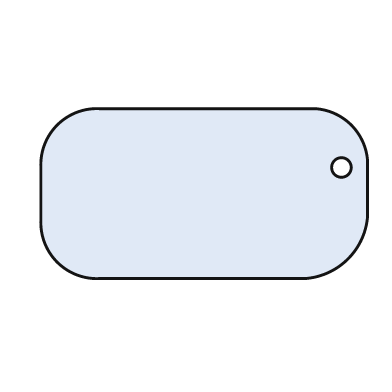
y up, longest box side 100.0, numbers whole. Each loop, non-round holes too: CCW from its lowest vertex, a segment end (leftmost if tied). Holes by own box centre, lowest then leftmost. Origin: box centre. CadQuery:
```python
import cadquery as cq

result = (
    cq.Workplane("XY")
    .moveTo(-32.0, -26.0)
    .lineTo(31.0, -26.0)
    .threePointArc((44.0, -20.0), (50.0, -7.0))
    .lineTo(50.0, 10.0)
    .threePointArc((45.0, 21.0), (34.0, 26.0))
    .lineTo(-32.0, 26.0)
    .threePointArc((-45.0, 21.0), (-50.0, 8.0))
    .lineTo(-50.0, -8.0)
    .threePointArc((-45.0, -21.0), (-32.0, -26.0))
    .close()
    .moveTo(42.0, 8.0)
    .circle(3.0)
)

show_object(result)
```